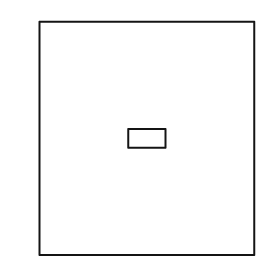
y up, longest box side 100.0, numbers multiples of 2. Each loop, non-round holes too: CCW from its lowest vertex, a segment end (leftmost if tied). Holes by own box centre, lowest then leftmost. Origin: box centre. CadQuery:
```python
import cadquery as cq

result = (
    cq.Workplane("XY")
    .moveTo(-46.0, -50.0)
    .lineTo(46.0, -50.0)
    .lineTo(46.0, 50.0)
    .lineTo(-46.0, 50.0)
    .close()
    .moveTo(-8.0, -4.0)
    .lineTo(8.0, -4.0)
    .lineTo(8.0, 4.0)
    .lineTo(-8.0, 4.0)
    .close()
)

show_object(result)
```